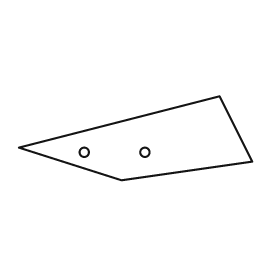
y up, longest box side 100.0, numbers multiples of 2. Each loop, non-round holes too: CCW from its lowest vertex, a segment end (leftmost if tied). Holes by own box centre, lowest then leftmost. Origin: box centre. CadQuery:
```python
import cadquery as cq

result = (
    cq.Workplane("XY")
    .moveTo(-6.0, -18.0)
    .lineTo(50.0, -10.0)
    .lineTo(36.0, 18.0)
    .lineTo(-50.0, -4.0)
    .close()
    .moveTo(-22.0, -6.0)
    .circle(2.0)
    .moveTo(4.0, -6.0)
    .circle(2.0)
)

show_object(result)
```